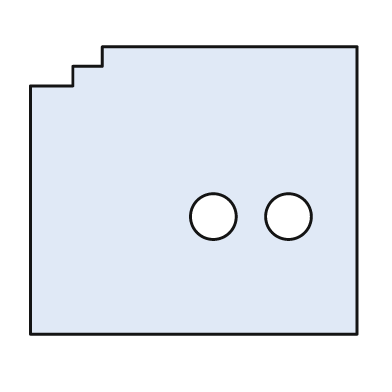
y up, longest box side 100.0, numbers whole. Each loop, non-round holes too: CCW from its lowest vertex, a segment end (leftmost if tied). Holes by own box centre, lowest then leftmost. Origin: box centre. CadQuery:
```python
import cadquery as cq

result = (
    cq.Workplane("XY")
    .moveTo(-50.0, -44.0)
    .lineTo(50.0, -44.0)
    .lineTo(50.0, 44.0)
    .lineTo(-28.0, 44.0)
    .lineTo(-28.0, 38.0)
    .lineTo(-37.0, 38.0)
    .lineTo(-37.0, 32.0)
    .lineTo(-50.0, 32.0)
    .close()
    .moveTo(6.0, -8.0)
    .circle(7.0)
    .moveTo(29.0, -8.0)
    .circle(7.0)
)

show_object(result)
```